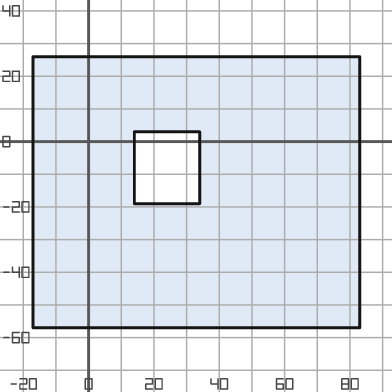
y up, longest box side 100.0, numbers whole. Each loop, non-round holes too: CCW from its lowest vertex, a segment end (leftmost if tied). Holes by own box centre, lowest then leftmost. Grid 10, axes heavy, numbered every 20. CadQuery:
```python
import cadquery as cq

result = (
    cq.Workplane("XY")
    .moveTo(-17.0, -57.0)
    .lineTo(83.0, -57.0)
    .lineTo(83.0, 26.0)
    .lineTo(-17.0, 26.0)
    .close()
    .moveTo(14.0, -19.0)
    .lineTo(34.0, -19.0)
    .lineTo(34.0, 3.0)
    .lineTo(14.0, 3.0)
    .close()
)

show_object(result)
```